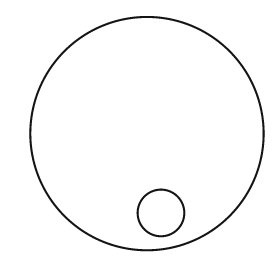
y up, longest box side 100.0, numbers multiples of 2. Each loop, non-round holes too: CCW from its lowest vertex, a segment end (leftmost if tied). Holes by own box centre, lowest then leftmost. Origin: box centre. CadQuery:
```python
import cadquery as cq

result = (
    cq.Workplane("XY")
    .moveTo(0.0, 0.0)
    .circle(50.0)
    .moveTo(6.0, -34.0)
    .circle(10.0)
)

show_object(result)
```